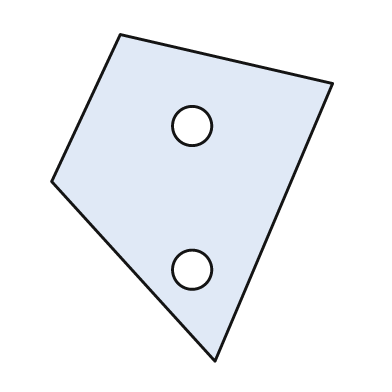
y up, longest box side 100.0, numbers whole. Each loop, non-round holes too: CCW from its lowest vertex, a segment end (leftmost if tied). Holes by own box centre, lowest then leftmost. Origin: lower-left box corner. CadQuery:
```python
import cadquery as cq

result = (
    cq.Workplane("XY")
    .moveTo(50.0, 0.0)
    .lineTo(86.0, 85.0)
    .lineTo(21.0, 100.0)
    .lineTo(0.0, 55.0)
    .close()
    .moveTo(43.0, 28.0)
    .circle(6.0)
    .moveTo(43.0, 72.0)
    .circle(6.0)
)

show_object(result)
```